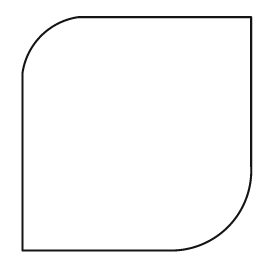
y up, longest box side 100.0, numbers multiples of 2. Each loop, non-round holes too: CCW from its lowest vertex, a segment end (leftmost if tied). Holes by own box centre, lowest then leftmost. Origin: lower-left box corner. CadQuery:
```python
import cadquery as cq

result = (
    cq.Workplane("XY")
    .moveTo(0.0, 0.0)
    .lineTo(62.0, 0.0)
    .threePointArc((88.0, 10.0), (98.0, 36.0))
    .lineTo(98.0, 100.0)
    .lineTo(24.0, 100.0)
    .threePointArc((8.0, 92.0), (0.0, 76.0))
    .close()
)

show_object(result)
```